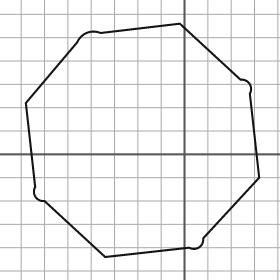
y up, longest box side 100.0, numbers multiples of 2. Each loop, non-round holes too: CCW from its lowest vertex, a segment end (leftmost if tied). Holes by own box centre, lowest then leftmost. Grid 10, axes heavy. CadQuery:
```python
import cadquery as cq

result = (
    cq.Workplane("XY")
    .moveTo(-34.0, -44.0)
    .lineTo(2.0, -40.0)
    .threePointArc((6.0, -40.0), (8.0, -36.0))
    .lineTo(32.0, -10.0)
    .lineTo(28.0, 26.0)
    .threePointArc((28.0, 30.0), (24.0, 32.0))
    .lineTo(-2.0, 56.0)
    .lineTo(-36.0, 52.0)
    .threePointArc((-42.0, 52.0), (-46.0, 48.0))
    .lineTo(-68.0, 22.0)
    .lineTo(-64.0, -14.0)
    .threePointArc((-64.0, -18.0), (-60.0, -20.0))
    .close()
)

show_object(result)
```